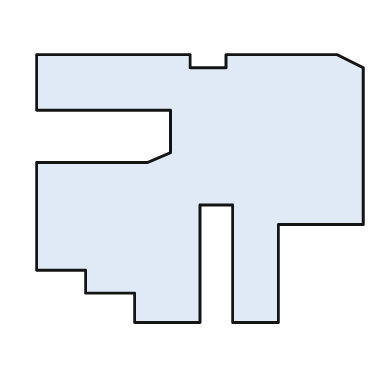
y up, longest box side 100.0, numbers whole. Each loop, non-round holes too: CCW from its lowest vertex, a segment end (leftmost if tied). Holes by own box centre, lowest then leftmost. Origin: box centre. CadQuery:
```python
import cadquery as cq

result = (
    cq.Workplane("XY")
    .moveTo(-20.0, -41.0)
    .lineTo(0.0, -41.0)
    .lineTo(0.0, -5.0)
    .lineTo(10.0, -5.0)
    .lineTo(10.0, -41.0)
    .lineTo(24.0, -41.0)
    .lineTo(24.0, -11.0)
    .lineTo(50.0, -11.0)
    .lineTo(50.0, 37.0)
    .lineTo(42.0, 41.0)
    .lineTo(8.0, 41.0)
    .lineTo(8.0, 37.0)
    .lineTo(-3.0, 37.0)
    .lineTo(-3.0, 41.0)
    .lineTo(-50.0, 41.0)
    .lineTo(-50.0, 24.0)
    .lineTo(-9.0, 24.0)
    .lineTo(-9.0, 11.0)
    .lineTo(-16.0, 8.0)
    .lineTo(-50.0, 8.0)
    .lineTo(-50.0, -25.0)
    .lineTo(-35.0, -25.0)
    .lineTo(-35.0, -32.0)
    .lineTo(-20.0, -32.0)
    .close()
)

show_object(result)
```